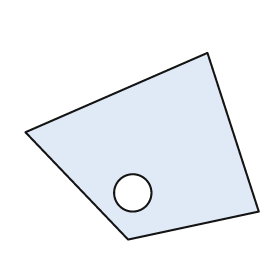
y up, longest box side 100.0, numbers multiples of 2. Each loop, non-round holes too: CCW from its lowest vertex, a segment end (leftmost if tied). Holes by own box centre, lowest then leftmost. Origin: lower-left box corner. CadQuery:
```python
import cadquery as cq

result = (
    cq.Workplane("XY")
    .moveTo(44.0, 0.0)
    .lineTo(100.0, 12.0)
    .lineTo(78.0, 80.0)
    .lineTo(0.0, 46.0)
    .close()
    .moveTo(46.0, 20.0)
    .circle(8.0)
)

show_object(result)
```